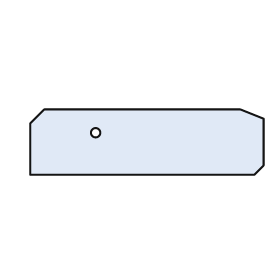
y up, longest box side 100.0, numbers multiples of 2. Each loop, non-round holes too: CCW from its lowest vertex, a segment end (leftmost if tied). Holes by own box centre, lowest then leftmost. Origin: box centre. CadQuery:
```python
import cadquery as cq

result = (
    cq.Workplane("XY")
    .moveTo(-50.0, -14.0)
    .lineTo(46.0, -14.0)
    .lineTo(50.0, -10.0)
    .lineTo(50.0, 10.0)
    .lineTo(40.0, 14.0)
    .lineTo(-44.0, 14.0)
    .lineTo(-50.0, 8.0)
    .close()
    .moveTo(-22.0, 4.0)
    .circle(2.0)
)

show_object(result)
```